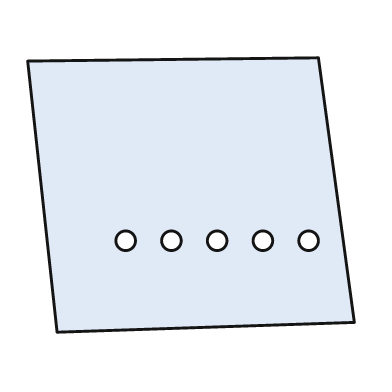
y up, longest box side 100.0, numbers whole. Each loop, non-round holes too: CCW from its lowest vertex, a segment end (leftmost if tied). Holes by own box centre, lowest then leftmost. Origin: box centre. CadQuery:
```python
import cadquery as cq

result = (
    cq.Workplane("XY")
    .moveTo(-41.0, -42.0)
    .lineTo(50.0, -39.0)
    .lineTo(39.0, 42.0)
    .lineTo(-50.0, 41.0)
    .close()
    .moveTo(-20.0, -14.0)
    .circle(3.0)
    .moveTo(-6.0, -14.0)
    .circle(3.0)
    .moveTo(8.0, -14.0)
    .circle(3.0)
    .moveTo(22.0, -14.0)
    .circle(3.0)
    .moveTo(36.0, -14.0)
    .circle(3.0)
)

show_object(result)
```